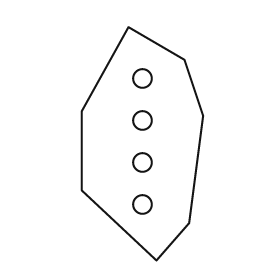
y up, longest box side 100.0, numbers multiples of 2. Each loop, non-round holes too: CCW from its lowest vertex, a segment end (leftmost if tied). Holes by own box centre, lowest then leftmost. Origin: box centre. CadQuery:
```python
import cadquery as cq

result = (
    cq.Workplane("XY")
    .moveTo(6.0, -50.0)
    .lineTo(20.0, -34.0)
    .lineTo(26.0, 12.0)
    .lineTo(18.0, 36.0)
    .lineTo(-6.0, 50.0)
    .lineTo(-26.0, 14.0)
    .lineTo(-26.0, -20.0)
    .close()
    .moveTo(0.0, -26.0)
    .circle(4.0)
    .moveTo(0.0, -8.0)
    .circle(4.0)
    .moveTo(0.0, 10.0)
    .circle(4.0)
    .moveTo(0.0, 28.0)
    .circle(4.0)
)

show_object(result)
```